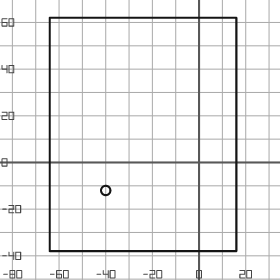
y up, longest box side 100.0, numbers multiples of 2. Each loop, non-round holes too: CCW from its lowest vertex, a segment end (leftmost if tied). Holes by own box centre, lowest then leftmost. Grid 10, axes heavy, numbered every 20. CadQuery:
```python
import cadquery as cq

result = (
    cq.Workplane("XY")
    .moveTo(-64.0, -38.0)
    .lineTo(16.0, -38.0)
    .lineTo(16.0, 62.0)
    .lineTo(-64.0, 62.0)
    .close()
    .moveTo(-40.0, -12.0)
    .circle(2.0)
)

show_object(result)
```